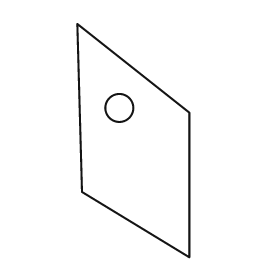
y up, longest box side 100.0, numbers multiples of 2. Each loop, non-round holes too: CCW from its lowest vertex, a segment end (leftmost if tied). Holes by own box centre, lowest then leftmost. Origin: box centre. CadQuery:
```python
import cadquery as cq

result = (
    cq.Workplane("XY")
    .moveTo(24.0, -50.0)
    .lineTo(24.0, 12.0)
    .lineTo(-24.0, 50.0)
    .lineTo(-22.0, -22.0)
    .close()
    .moveTo(-6.0, 14.0)
    .circle(6.0)
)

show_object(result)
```